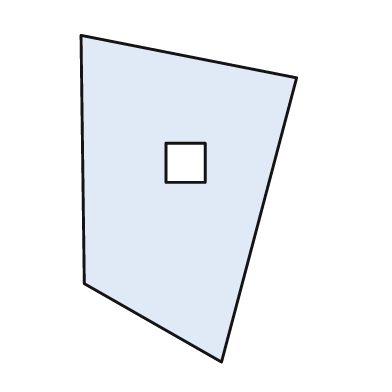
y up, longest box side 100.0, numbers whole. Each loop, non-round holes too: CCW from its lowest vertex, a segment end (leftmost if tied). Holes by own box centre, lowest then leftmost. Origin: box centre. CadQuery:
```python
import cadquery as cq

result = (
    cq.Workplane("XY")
    .moveTo(10.0, -50.0)
    .lineTo(33.0, 37.0)
    .lineTo(-33.0, 50.0)
    .lineTo(-32.0, -26.0)
    .close()
    .moveTo(-7.0, 5.0)
    .lineTo(5.0, 5.0)
    .lineTo(5.0, 17.0)
    .lineTo(-7.0, 17.0)
    .close()
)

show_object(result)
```